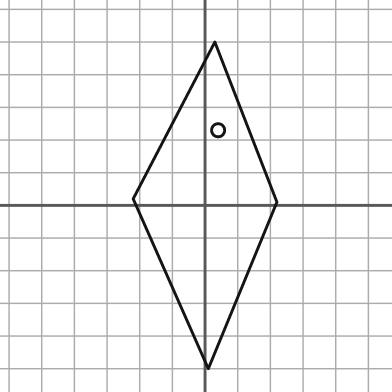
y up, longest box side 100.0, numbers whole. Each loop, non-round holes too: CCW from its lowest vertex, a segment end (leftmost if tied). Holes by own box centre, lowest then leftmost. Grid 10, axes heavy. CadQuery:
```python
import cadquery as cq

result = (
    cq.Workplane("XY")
    .moveTo(1.0, -50.0)
    .lineTo(22.0, 1.0)
    .lineTo(3.0, 50.0)
    .lineTo(-22.0, 2.0)
    .close()
    .moveTo(4.0, 23.0)
    .circle(2.0)
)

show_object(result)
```